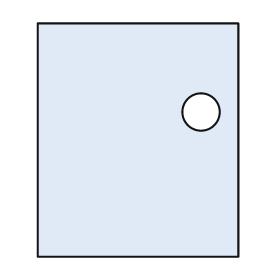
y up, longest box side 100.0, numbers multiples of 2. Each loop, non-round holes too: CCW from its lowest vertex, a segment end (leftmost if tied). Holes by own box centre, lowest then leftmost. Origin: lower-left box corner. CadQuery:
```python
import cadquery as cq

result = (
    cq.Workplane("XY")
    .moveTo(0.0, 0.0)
    .lineTo(86.0, 0.0)
    .lineTo(86.0, 100.0)
    .lineTo(0.0, 100.0)
    .close()
    .moveTo(70.0, 62.0)
    .circle(8.0)
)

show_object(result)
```